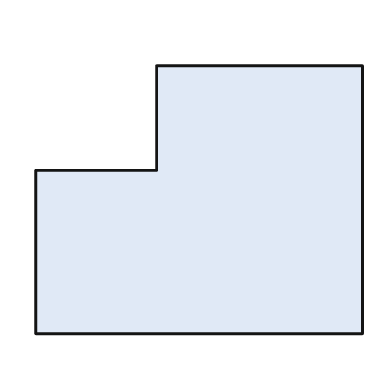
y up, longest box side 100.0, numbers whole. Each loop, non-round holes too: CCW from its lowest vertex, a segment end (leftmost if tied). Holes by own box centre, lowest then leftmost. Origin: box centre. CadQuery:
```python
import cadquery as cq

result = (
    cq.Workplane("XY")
    .moveTo(-50.0, -41.0)
    .lineTo(50.0, -41.0)
    .lineTo(50.0, 41.0)
    .lineTo(-13.0, 41.0)
    .lineTo(-13.0, 9.0)
    .lineTo(-50.0, 9.0)
    .close()
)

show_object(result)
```